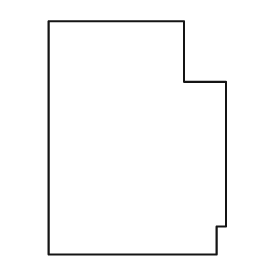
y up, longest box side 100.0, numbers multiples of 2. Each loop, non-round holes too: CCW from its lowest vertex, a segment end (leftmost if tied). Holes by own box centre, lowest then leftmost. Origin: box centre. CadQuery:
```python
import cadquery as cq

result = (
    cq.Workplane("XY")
    .moveTo(-38.0, -50.0)
    .lineTo(34.0, -50.0)
    .lineTo(34.0, -38.0)
    .lineTo(38.0, -38.0)
    .lineTo(38.0, 24.0)
    .lineTo(20.0, 24.0)
    .lineTo(20.0, 50.0)
    .lineTo(-38.0, 50.0)
    .close()
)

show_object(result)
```